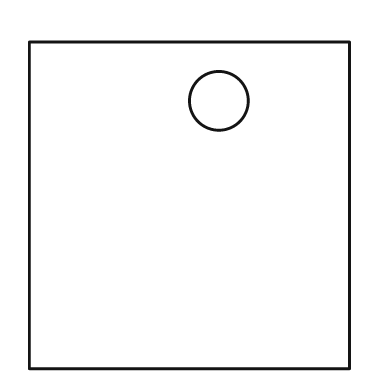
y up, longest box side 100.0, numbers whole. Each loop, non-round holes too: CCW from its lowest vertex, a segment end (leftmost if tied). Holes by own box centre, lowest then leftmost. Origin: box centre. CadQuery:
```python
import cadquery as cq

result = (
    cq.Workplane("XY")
    .moveTo(-49.0, -50.0)
    .lineTo(49.0, -50.0)
    .lineTo(49.0, 50.0)
    .lineTo(-49.0, 50.0)
    .close()
    .moveTo(9.0, 32.0)
    .circle(9.0)
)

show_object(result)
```